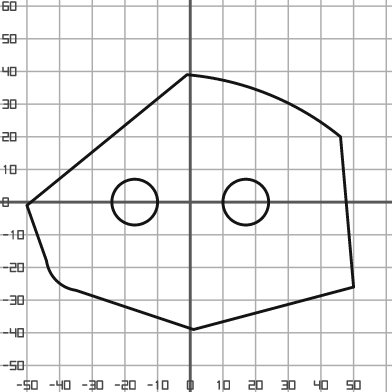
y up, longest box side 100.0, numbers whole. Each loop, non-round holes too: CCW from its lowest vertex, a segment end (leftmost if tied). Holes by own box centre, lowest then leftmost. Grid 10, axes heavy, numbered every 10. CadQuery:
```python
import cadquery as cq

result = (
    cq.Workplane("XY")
    .moveTo(1.0, -39.0)
    .lineTo(50.0, -26.0)
    .lineTo(46.0, 20.0)
    .threePointArc((24.0, 33.0), (-1.0, 39.0))
    .lineTo(-50.0, -1.0)
    .lineTo(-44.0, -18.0)
    .threePointArc((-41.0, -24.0), (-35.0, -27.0))
    .close()
    .moveTo(-17.0, 0.0)
    .circle(7.0)
    .moveTo(17.0, 0.0)
    .circle(7.0)
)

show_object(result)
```